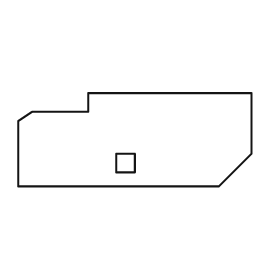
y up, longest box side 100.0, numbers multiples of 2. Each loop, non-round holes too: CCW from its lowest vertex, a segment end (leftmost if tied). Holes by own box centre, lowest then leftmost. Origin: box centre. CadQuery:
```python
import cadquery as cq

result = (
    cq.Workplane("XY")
    .moveTo(-50.0, -20.0)
    .lineTo(36.0, -20.0)
    .lineTo(50.0, -6.0)
    .lineTo(50.0, 20.0)
    .lineTo(-20.0, 20.0)
    .lineTo(-20.0, 12.0)
    .lineTo(-44.0, 12.0)
    .lineTo(-50.0, 8.0)
    .close()
    .moveTo(-8.0, -14.0)
    .lineTo(0.0, -14.0)
    .lineTo(0.0, -6.0)
    .lineTo(-8.0, -6.0)
    .close()
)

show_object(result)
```